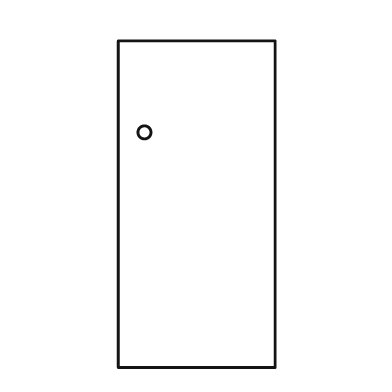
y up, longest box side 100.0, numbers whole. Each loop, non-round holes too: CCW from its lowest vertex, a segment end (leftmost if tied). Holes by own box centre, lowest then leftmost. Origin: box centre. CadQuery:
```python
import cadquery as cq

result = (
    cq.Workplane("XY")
    .moveTo(-24.0, -50.0)
    .lineTo(24.0, -50.0)
    .lineTo(24.0, 50.0)
    .lineTo(-24.0, 50.0)
    .close()
    .moveTo(-16.0, 22.0)
    .circle(2.0)
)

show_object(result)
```